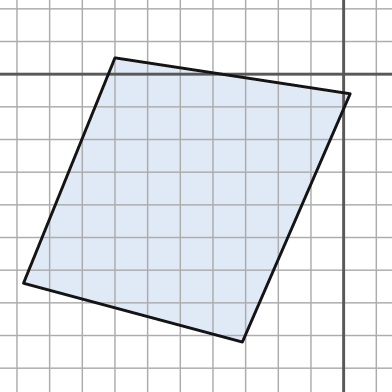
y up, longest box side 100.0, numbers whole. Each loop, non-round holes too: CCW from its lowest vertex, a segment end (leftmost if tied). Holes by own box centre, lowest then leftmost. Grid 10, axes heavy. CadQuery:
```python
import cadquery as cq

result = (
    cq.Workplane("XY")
    .moveTo(-31.0, -82.0)
    .lineTo(2.0, -6.0)
    .lineTo(-70.0, 5.0)
    .lineTo(-98.0, -64.0)
    .close()
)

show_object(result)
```